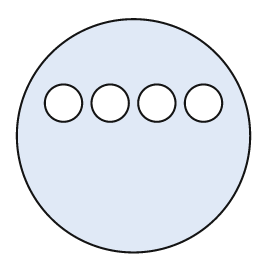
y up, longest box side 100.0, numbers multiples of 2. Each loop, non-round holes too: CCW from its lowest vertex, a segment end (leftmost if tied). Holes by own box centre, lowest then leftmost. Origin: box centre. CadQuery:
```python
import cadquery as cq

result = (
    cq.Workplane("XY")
    .moveTo(0.0, 0.0)
    .circle(50.0)
    .moveTo(-30.0, 14.0)
    .circle(8.0)
    .moveTo(-10.0, 14.0)
    .circle(8.0)
    .moveTo(10.0, 14.0)
    .circle(8.0)
    .moveTo(30.0, 14.0)
    .circle(8.0)
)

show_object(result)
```